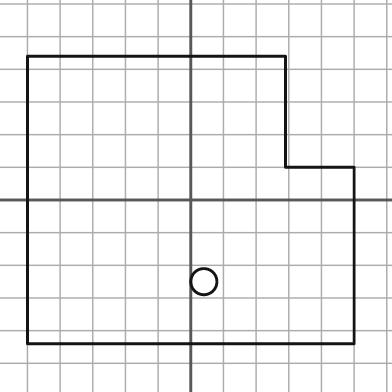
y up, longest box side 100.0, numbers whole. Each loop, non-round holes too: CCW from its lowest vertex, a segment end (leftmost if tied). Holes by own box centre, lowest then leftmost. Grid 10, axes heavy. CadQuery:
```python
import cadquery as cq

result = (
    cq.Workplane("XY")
    .moveTo(-50.0, -44.0)
    .lineTo(50.0, -44.0)
    .lineTo(50.0, 10.0)
    .lineTo(29.0, 10.0)
    .lineTo(29.0, 44.0)
    .lineTo(-50.0, 44.0)
    .close()
    .moveTo(4.0, -25.0)
    .circle(4.0)
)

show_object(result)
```